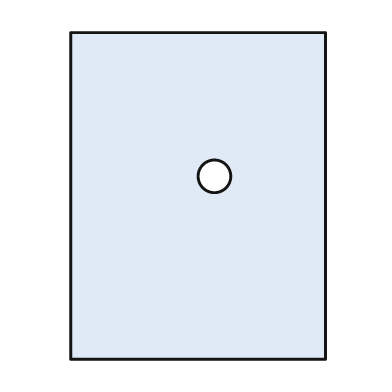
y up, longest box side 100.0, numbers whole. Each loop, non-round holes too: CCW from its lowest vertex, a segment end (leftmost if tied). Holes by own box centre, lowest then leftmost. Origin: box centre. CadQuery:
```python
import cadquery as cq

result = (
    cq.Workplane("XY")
    .moveTo(-39.0, -50.0)
    .lineTo(39.0, -50.0)
    .lineTo(39.0, 50.0)
    .lineTo(-39.0, 50.0)
    .close()
    .moveTo(5.0, 6.0)
    .circle(5.0)
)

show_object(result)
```